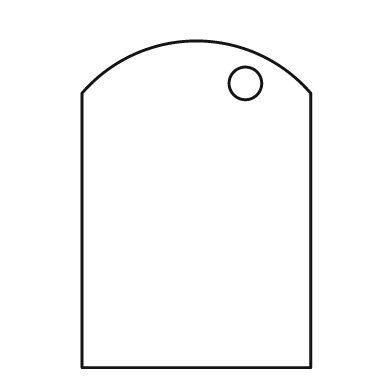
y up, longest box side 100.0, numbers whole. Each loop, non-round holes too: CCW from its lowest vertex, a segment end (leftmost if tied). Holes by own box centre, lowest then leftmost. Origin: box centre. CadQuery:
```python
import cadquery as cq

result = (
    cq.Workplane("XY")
    .moveTo(-35.0, -50.0)
    .lineTo(35.0, -50.0)
    .lineTo(35.0, 34.0)
    .threePointArc((0.0, 50.0), (-35.0, 34.0))
    .close()
    .moveTo(15.0, 37.0)
    .circle(5.0)
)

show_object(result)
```